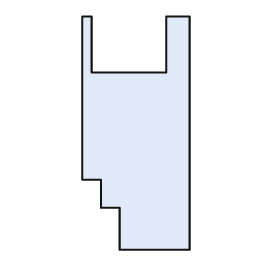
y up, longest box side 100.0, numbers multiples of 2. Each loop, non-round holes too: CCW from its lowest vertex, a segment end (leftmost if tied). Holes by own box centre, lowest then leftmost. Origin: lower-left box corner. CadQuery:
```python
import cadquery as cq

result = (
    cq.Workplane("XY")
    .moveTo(16.0, 0.0)
    .lineTo(46.0, 0.0)
    .lineTo(46.0, 100.0)
    .lineTo(36.0, 100.0)
    .lineTo(36.0, 76.0)
    .lineTo(4.0, 76.0)
    .lineTo(4.0, 100.0)
    .lineTo(0.0, 100.0)
    .lineTo(0.0, 30.0)
    .lineTo(8.0, 30.0)
    .lineTo(8.0, 18.0)
    .lineTo(16.0, 18.0)
    .close()
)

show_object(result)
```